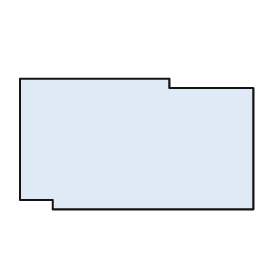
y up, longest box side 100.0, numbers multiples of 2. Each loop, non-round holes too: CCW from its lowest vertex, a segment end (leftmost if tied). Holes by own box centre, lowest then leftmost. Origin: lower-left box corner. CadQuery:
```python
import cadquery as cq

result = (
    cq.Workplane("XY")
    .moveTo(14.0, 0.0)
    .lineTo(100.0, 0.0)
    .lineTo(100.0, 52.0)
    .lineTo(64.0, 52.0)
    .lineTo(64.0, 56.0)
    .lineTo(0.0, 56.0)
    .lineTo(0.0, 4.0)
    .lineTo(14.0, 4.0)
    .close()
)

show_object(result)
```